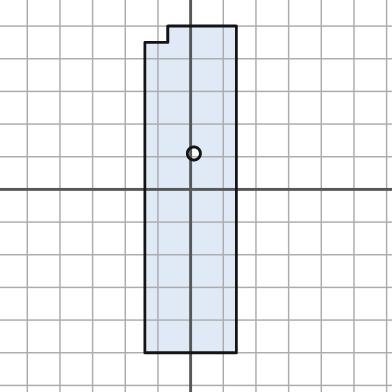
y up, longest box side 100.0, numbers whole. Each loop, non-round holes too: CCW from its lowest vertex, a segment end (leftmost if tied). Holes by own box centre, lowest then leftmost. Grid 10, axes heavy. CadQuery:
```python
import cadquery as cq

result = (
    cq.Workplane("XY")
    .moveTo(-14.0, -50.0)
    .lineTo(14.0, -50.0)
    .lineTo(14.0, 50.0)
    .lineTo(-7.0, 50.0)
    .lineTo(-7.0, 45.0)
    .lineTo(-14.0, 45.0)
    .close()
    .moveTo(1.0, 11.0)
    .circle(2.0)
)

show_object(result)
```